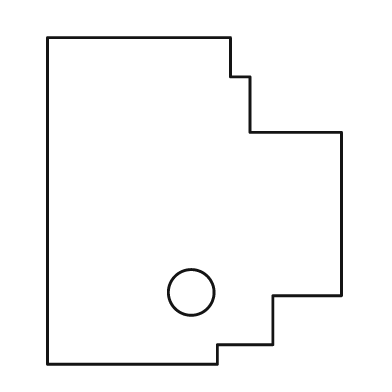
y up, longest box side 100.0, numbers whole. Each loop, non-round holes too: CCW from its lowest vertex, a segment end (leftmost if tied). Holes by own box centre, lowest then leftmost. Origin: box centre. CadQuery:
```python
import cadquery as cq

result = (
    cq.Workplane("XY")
    .moveTo(-45.0, -50.0)
    .lineTo(7.0, -50.0)
    .lineTo(7.0, -44.0)
    .lineTo(24.0, -44.0)
    .lineTo(24.0, -29.0)
    .lineTo(45.0, -29.0)
    .lineTo(45.0, 21.0)
    .lineTo(17.0, 21.0)
    .lineTo(17.0, 38.0)
    .lineTo(11.0, 38.0)
    .lineTo(11.0, 50.0)
    .lineTo(-45.0, 50.0)
    .close()
    .moveTo(-1.0, -28.0)
    .circle(7.0)
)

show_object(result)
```